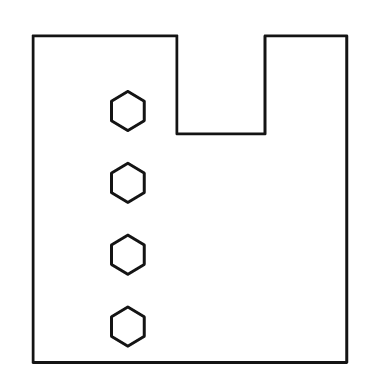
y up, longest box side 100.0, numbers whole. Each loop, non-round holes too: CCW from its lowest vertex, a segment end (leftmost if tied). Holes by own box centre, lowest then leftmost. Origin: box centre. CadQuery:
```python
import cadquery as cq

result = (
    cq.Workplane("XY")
    .moveTo(-48.0, -50.0)
    .lineTo(48.0, -50.0)
    .lineTo(48.0, 50.0)
    .lineTo(23.0, 50.0)
    .lineTo(23.0, 20.0)
    .lineTo(-4.0, 20.0)
    .lineTo(-4.0, 50.0)
    .lineTo(-48.0, 50.0)
    .close()
    .moveTo(-19.0, -45.0)
    .lineTo(-14.0, -42.0)
    .lineTo(-14.0, -36.0)
    .lineTo(-19.0, -33.0)
    .lineTo(-24.0, -36.0)
    .lineTo(-24.0, -42.0)
    .close()
    .moveTo(-19.0, -23.0)
    .lineTo(-14.0, -20.0)
    .lineTo(-14.0, -14.0)
    .lineTo(-19.0, -11.0)
    .lineTo(-24.0, -14.0)
    .lineTo(-24.0, -20.0)
    .close()
    .moveTo(-19.0, -1.0)
    .lineTo(-14.0, 2.0)
    .lineTo(-14.0, 8.0)
    .lineTo(-19.0, 11.0)
    .lineTo(-24.0, 8.0)
    .lineTo(-24.0, 2.0)
    .close()
    .moveTo(-19.0, 21.0)
    .lineTo(-14.0, 24.0)
    .lineTo(-14.0, 30.0)
    .lineTo(-19.0, 33.0)
    .lineTo(-24.0, 30.0)
    .lineTo(-24.0, 24.0)
    .close()
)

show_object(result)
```